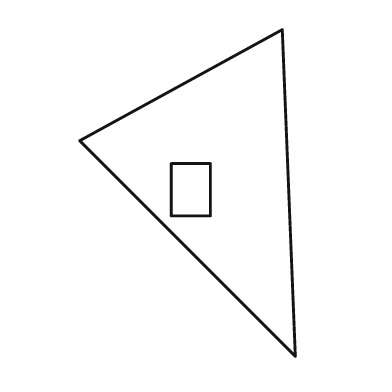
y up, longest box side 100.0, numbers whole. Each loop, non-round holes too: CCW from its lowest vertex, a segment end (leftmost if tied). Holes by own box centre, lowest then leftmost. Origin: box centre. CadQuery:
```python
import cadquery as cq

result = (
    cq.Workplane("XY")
    .moveTo(33.0, -50.0)
    .lineTo(29.0, 50.0)
    .lineTo(-33.0, 16.0)
    .close()
    .moveTo(-5.0, -7.0)
    .lineTo(7.0, -7.0)
    .lineTo(7.0, 9.0)
    .lineTo(-5.0, 9.0)
    .close()
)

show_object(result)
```